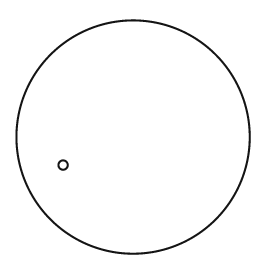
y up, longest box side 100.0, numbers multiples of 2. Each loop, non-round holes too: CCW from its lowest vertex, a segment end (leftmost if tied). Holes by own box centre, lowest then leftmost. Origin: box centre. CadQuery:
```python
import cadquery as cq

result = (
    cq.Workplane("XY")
    .moveTo(0.0, 0.0)
    .circle(50.0)
    .moveTo(-30.0, -12.0)
    .circle(2.0)
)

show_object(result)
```